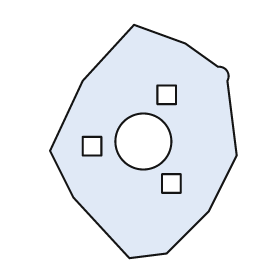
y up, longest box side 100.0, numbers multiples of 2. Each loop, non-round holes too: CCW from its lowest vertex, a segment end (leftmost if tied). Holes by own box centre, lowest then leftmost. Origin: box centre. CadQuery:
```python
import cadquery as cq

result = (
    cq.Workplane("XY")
    .moveTo(-6.0, -50.0)
    .lineTo(10.0, -48.0)
    .lineTo(28.0, -30.0)
    .lineTo(40.0, -6.0)
    .lineTo(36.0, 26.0)
    .threePointArc((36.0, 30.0), (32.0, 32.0))
    .lineTo(18.0, 42.0)
    .lineTo(-4.0, 50.0)
    .lineTo(-26.0, 26.0)
    .lineTo(-40.0, -4.0)
    .lineTo(-30.0, -24.0)
    .close()
    .moveTo(8.0, -22.0)
    .lineTo(16.0, -22.0)
    .lineTo(16.0, -14.0)
    .lineTo(8.0, -14.0)
    .close()
    .moveTo(-26.0, -6.0)
    .lineTo(-18.0, -6.0)
    .lineTo(-18.0, 2.0)
    .lineTo(-26.0, 2.0)
    .close()
    .moveTo(0.0, 0.0)
    .circle(12.0)
    .moveTo(6.0, 16.0)
    .lineTo(14.0, 16.0)
    .lineTo(14.0, 24.0)
    .lineTo(6.0, 24.0)
    .close()
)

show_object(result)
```